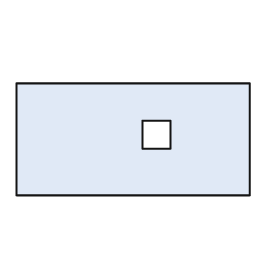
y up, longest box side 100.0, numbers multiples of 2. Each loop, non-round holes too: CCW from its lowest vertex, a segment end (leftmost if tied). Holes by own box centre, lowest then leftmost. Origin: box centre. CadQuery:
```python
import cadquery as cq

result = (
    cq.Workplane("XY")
    .moveTo(-50.0, -24.0)
    .lineTo(50.0, -24.0)
    .lineTo(50.0, 24.0)
    .lineTo(-50.0, 24.0)
    .close()
    .moveTo(4.0, -4.0)
    .lineTo(16.0, -4.0)
    .lineTo(16.0, 8.0)
    .lineTo(4.0, 8.0)
    .close()
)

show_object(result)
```